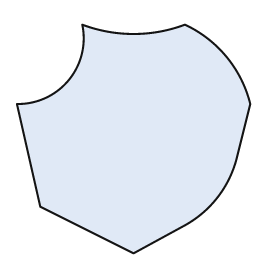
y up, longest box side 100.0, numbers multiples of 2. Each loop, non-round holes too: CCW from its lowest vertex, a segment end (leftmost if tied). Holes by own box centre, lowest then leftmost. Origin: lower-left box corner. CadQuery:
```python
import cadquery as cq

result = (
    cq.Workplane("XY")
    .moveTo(50.0, 0.0)
    .lineTo(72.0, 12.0)
    .threePointArc((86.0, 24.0), (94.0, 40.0))
    .lineTo(100.0, 64.0)
    .threePointArc((90.0, 84.0), (72.0, 98.0))
    .threePointArc((50.0, 94.0), (28.0, 98.0))
    .threePointArc((22.0, 74.0), (0.0, 64.0))
    .lineTo(10.0, 20.0)
    .close()
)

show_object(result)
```